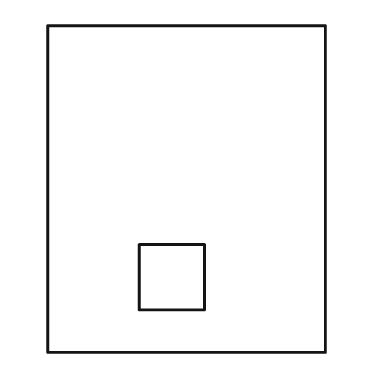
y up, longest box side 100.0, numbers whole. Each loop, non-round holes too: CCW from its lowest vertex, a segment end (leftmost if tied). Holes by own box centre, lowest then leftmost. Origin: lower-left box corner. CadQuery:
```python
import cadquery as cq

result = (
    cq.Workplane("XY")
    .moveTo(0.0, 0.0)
    .lineTo(85.0, 0.0)
    .lineTo(85.0, 100.0)
    .lineTo(0.0, 100.0)
    .close()
    .moveTo(28.0, 13.0)
    .lineTo(48.0, 13.0)
    .lineTo(48.0, 33.0)
    .lineTo(28.0, 33.0)
    .close()
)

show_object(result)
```